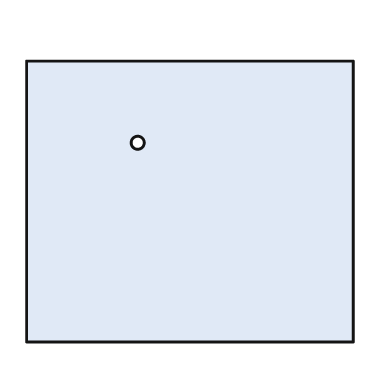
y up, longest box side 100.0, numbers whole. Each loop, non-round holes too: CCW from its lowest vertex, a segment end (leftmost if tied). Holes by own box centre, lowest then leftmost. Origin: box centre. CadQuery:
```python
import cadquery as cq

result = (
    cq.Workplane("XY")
    .moveTo(-50.0, -43.0)
    .lineTo(50.0, -43.0)
    .lineTo(50.0, 43.0)
    .lineTo(-50.0, 43.0)
    .close()
    .moveTo(-16.0, 18.0)
    .circle(2.0)
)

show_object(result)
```